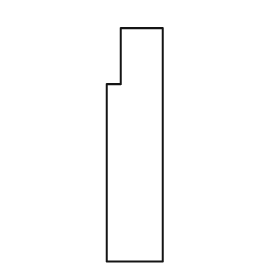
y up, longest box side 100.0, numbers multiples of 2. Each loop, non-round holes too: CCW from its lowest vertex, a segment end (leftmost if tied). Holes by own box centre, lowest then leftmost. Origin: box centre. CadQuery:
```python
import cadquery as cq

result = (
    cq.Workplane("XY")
    .moveTo(-12.0, -50.0)
    .lineTo(12.0, -50.0)
    .lineTo(12.0, 50.0)
    .lineTo(-6.0, 50.0)
    .lineTo(-6.0, 26.0)
    .lineTo(-12.0, 26.0)
    .close()
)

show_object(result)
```